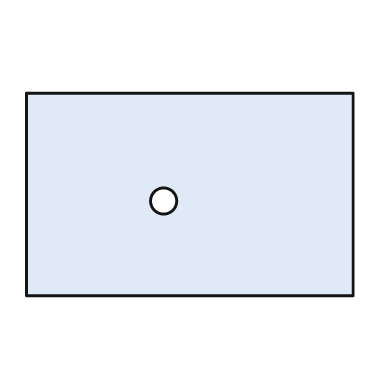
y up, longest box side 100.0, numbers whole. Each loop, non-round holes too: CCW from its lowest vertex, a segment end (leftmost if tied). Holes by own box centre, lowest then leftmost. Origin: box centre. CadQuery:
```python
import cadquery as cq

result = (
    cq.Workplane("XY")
    .moveTo(-50.0, -31.0)
    .lineTo(50.0, -31.0)
    .lineTo(50.0, 31.0)
    .lineTo(-50.0, 31.0)
    .close()
    .moveTo(-8.0, -2.0)
    .circle(4.0)
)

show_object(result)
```